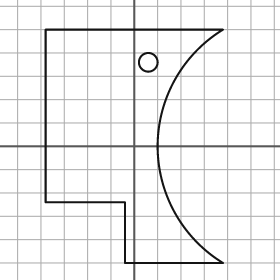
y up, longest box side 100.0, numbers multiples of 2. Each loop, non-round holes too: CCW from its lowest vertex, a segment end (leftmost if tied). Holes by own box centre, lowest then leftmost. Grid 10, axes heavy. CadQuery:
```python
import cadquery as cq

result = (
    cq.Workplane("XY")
    .moveTo(-4.0, -50.0)
    .lineTo(38.0, -50.0)
    .threePointArc((10.0, 0.0), (38.0, 50.0))
    .lineTo(-38.0, 50.0)
    .lineTo(-38.0, -24.0)
    .lineTo(-4.0, -24.0)
    .close()
    .moveTo(6.0, 36.0)
    .circle(4.0)
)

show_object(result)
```